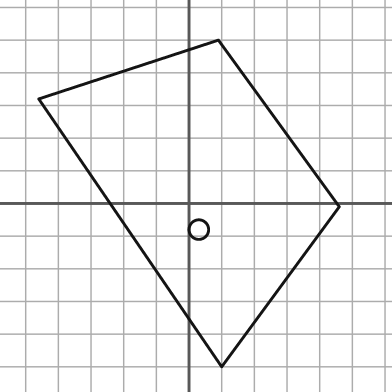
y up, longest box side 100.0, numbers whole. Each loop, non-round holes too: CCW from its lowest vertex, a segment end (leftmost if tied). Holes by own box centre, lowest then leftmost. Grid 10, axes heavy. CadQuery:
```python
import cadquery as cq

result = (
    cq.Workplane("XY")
    .moveTo(10.0, -50.0)
    .lineTo(46.0, -1.0)
    .lineTo(9.0, 50.0)
    .lineTo(-46.0, 32.0)
    .close()
    .moveTo(3.0, -8.0)
    .circle(3.0)
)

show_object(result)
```